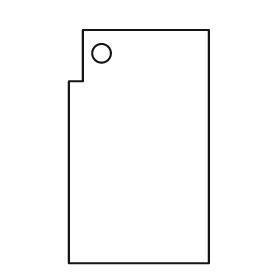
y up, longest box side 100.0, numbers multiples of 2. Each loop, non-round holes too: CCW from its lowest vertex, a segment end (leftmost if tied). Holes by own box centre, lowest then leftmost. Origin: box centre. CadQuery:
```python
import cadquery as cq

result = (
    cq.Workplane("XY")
    .moveTo(-30.0, -50.0)
    .lineTo(30.0, -50.0)
    .lineTo(30.0, 50.0)
    .lineTo(-24.0, 50.0)
    .lineTo(-24.0, 28.0)
    .lineTo(-30.0, 28.0)
    .close()
    .moveTo(-16.0, 40.0)
    .circle(4.0)
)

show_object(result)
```